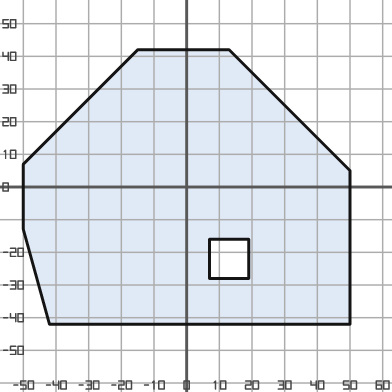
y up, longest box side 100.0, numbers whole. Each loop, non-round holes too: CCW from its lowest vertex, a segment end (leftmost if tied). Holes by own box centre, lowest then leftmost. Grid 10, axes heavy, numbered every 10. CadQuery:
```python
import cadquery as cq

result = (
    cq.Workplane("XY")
    .moveTo(-42.0, -42.0)
    .lineTo(50.0, -42.0)
    .lineTo(50.0, 5.0)
    .lineTo(13.0, 42.0)
    .lineTo(-15.0, 42.0)
    .lineTo(-50.0, 7.0)
    .lineTo(-50.0, -13.0)
    .close()
    .moveTo(7.0, -28.0)
    .lineTo(19.0, -28.0)
    .lineTo(19.0, -16.0)
    .lineTo(7.0, -16.0)
    .close()
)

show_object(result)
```